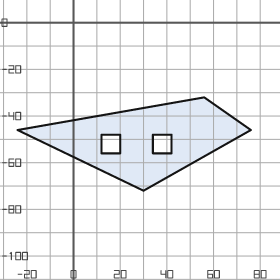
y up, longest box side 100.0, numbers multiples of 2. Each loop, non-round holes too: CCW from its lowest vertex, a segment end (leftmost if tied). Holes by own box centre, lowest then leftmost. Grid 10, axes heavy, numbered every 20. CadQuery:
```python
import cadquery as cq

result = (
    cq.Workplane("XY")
    .moveTo(30.0, -72.0)
    .lineTo(76.0, -46.0)
    .lineTo(56.0, -32.0)
    .lineTo(-24.0, -46.0)
    .close()
    .moveTo(12.0, -56.0)
    .lineTo(20.0, -56.0)
    .lineTo(20.0, -48.0)
    .lineTo(12.0, -48.0)
    .close()
    .moveTo(34.0, -56.0)
    .lineTo(42.0, -56.0)
    .lineTo(42.0, -48.0)
    .lineTo(34.0, -48.0)
    .close()
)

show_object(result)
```